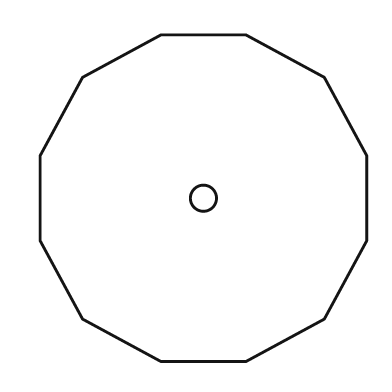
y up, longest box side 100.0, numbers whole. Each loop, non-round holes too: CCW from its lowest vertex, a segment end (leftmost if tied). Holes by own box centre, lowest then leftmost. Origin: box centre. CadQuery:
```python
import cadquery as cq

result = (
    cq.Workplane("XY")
    .moveTo(-13.0, -50.0)
    .lineTo(13.0, -50.0)
    .lineTo(37.0, -37.0)
    .lineTo(50.0, -13.0)
    .lineTo(50.0, 13.0)
    .lineTo(37.0, 37.0)
    .lineTo(13.0, 50.0)
    .lineTo(-13.0, 50.0)
    .lineTo(-37.0, 37.0)
    .lineTo(-50.0, 13.0)
    .lineTo(-50.0, -13.0)
    .lineTo(-37.0, -37.0)
    .close()
    .moveTo(0.0, 0.0)
    .circle(4.0)
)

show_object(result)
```